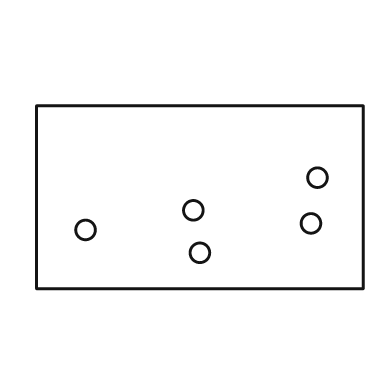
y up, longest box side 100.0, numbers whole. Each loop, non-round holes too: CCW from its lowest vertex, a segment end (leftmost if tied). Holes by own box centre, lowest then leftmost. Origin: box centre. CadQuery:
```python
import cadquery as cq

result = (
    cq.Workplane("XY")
    .moveTo(-50.0, -28.0)
    .lineTo(50.0, -28.0)
    .lineTo(50.0, 28.0)
    .lineTo(-50.0, 28.0)
    .close()
    .moveTo(0.0, -17.0)
    .circle(3.0)
    .moveTo(-35.0, -10.0)
    .circle(3.0)
    .moveTo(34.0, -8.0)
    .circle(3.0)
    .moveTo(-2.0, -4.0)
    .circle(3.0)
    .moveTo(36.0, 6.0)
    .circle(3.0)
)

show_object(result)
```